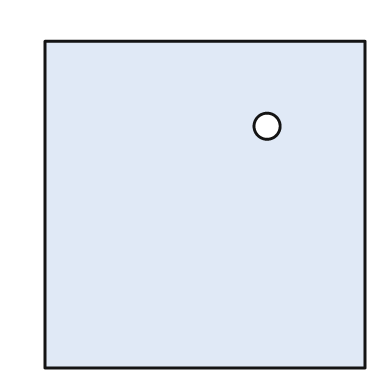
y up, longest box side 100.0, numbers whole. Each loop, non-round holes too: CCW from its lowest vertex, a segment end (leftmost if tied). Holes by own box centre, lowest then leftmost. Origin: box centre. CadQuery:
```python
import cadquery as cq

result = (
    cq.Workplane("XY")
    .moveTo(-49.0, -50.0)
    .lineTo(49.0, -50.0)
    .lineTo(49.0, 50.0)
    .lineTo(-49.0, 50.0)
    .close()
    .moveTo(19.0, 24.0)
    .circle(4.0)
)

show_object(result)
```